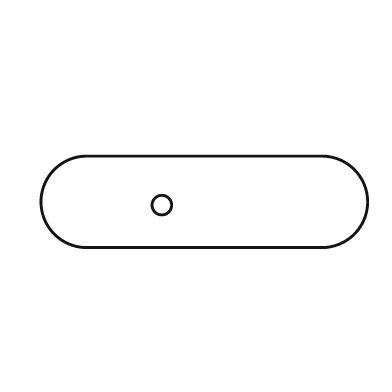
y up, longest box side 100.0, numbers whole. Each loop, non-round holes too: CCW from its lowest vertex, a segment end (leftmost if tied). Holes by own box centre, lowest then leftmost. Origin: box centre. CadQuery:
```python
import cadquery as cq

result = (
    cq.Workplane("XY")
    .moveTo(-36.0, -14.0)
    .lineTo(36.0, -14.0)
    .threePointArc((50.0, 0.0), (36.0, 14.0))
    .lineTo(-36.0, 14.0)
    .threePointArc((-50.0, 0.0), (-36.0, -14.0))
    .close()
    .moveTo(-13.0, -1.0)
    .circle(3.0)
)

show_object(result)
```